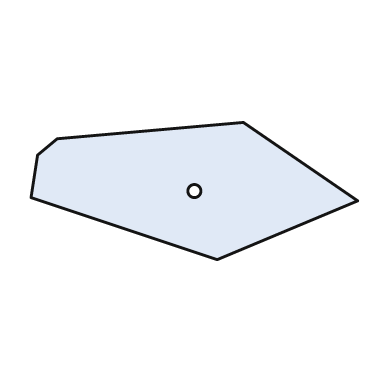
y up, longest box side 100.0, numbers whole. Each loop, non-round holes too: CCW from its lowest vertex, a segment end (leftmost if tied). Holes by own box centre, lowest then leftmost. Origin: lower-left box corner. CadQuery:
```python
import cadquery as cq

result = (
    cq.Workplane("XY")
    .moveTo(57.0, 0.0)
    .lineTo(100.0, 18.0)
    .lineTo(65.0, 42.0)
    .lineTo(8.0, 37.0)
    .lineTo(2.0, 32.0)
    .lineTo(0.0, 19.0)
    .close()
    .moveTo(50.0, 21.0)
    .circle(2.0)
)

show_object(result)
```